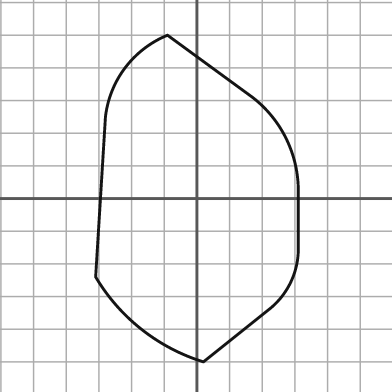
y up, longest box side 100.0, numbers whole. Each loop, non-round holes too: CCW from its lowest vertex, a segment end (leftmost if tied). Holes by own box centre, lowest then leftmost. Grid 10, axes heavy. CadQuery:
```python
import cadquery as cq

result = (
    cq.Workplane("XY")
    .moveTo(2.0, -50.0)
    .lineTo(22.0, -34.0)
    .threePointArc((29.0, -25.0), (31.0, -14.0))
    .lineTo(31.0, 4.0)
    .threePointArc((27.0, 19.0), (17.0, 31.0))
    .lineTo(-9.0, 50.0)
    .threePointArc((-22.0, 40.0), (-28.0, 25.0))
    .lineTo(-31.0, -24.0)
    .threePointArc((-17.0, -40.0), (2.0, -50.0))
    .close()
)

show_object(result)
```